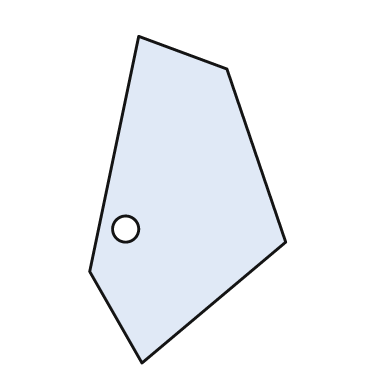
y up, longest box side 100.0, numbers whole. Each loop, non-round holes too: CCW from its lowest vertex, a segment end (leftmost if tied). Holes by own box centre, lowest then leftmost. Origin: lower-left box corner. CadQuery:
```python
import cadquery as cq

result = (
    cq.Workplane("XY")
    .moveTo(16.0, 0.0)
    .lineTo(60.0, 37.0)
    .lineTo(42.0, 90.0)
    .lineTo(15.0, 100.0)
    .lineTo(0.0, 28.0)
    .close()
    .moveTo(11.0, 41.0)
    .circle(4.0)
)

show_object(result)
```